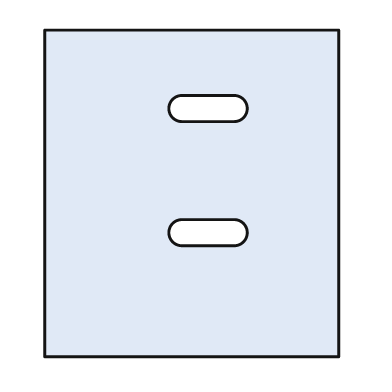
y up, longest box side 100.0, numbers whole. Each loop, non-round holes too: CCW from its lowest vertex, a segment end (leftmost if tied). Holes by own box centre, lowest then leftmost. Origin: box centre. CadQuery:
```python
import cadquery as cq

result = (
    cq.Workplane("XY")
    .moveTo(-45.0, -50.0)
    .lineTo(45.0, -50.0)
    .lineTo(45.0, 50.0)
    .lineTo(-45.0, 50.0)
    .close()
    .moveTo(-3.0, -16.0)
    .lineTo(13.0, -16.0)
    .threePointArc((17.0, -12.0), (13.0, -8.0))
    .lineTo(-3.0, -8.0)
    .threePointArc((-7.0, -12.0), (-3.0, -16.0))
    .close()
    .moveTo(-3.0, 22.0)
    .lineTo(13.0, 22.0)
    .threePointArc((17.0, 26.0), (13.0, 30.0))
    .lineTo(-3.0, 30.0)
    .threePointArc((-7.0, 26.0), (-3.0, 22.0))
    .close()
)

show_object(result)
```